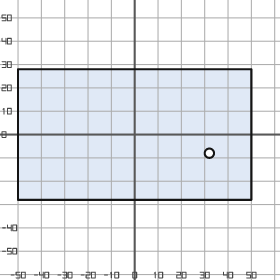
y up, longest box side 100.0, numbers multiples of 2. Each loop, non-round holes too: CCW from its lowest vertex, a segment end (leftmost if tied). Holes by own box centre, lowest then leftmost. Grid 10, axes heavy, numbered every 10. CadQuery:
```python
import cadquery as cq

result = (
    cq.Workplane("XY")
    .moveTo(-50.0, -28.0)
    .lineTo(50.0, -28.0)
    .lineTo(50.0, 28.0)
    .lineTo(-50.0, 28.0)
    .close()
    .moveTo(32.0, -8.0)
    .circle(2.0)
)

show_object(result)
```